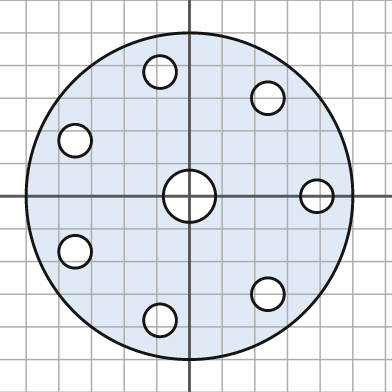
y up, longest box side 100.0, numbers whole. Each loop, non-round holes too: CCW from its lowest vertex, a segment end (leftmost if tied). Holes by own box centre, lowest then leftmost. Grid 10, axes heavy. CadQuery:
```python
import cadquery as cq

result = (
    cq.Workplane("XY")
    .moveTo(0.0, 0.0)
    .circle(50.0)
    .moveTo(-9.0, -38.0)
    .circle(5.0)
    .moveTo(24.0, -30.0)
    .circle(5.0)
    .moveTo(-35.0, -17.0)
    .circle(5.0)
    .moveTo(0.0, 0.0)
    .circle(8.0)
    .moveTo(39.0, 0.0)
    .circle(5.0)
    .moveTo(-35.0, 17.0)
    .circle(5.0)
    .moveTo(24.0, 30.0)
    .circle(5.0)
    .moveTo(-9.0, 38.0)
    .circle(5.0)
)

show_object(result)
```